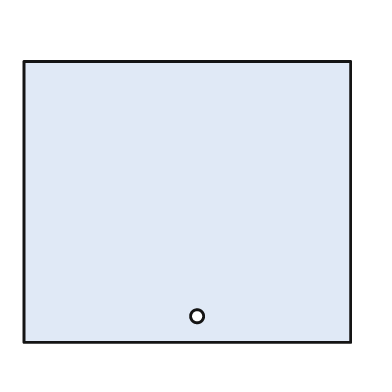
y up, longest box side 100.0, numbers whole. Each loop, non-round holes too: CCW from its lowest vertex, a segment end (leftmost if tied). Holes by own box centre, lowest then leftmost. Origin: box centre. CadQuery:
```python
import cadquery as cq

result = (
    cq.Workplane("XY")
    .moveTo(-50.0, -43.0)
    .lineTo(50.0, -43.0)
    .lineTo(50.0, 43.0)
    .lineTo(-50.0, 43.0)
    .close()
    .moveTo(3.0, -35.0)
    .circle(2.0)
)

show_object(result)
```